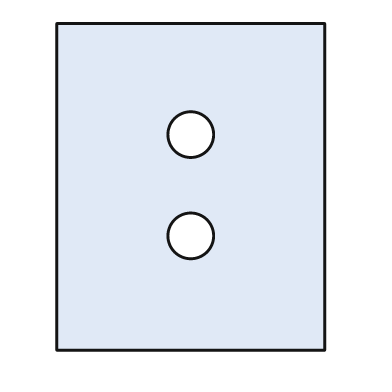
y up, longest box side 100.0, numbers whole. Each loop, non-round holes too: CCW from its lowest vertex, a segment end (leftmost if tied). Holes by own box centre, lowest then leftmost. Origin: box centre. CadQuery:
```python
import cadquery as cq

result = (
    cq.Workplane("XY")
    .moveTo(-41.0, -50.0)
    .lineTo(41.0, -50.0)
    .lineTo(41.0, 50.0)
    .lineTo(-41.0, 50.0)
    .close()
    .moveTo(0.0, -15.0)
    .circle(7.0)
    .moveTo(0.0, 16.0)
    .circle(7.0)
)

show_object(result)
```